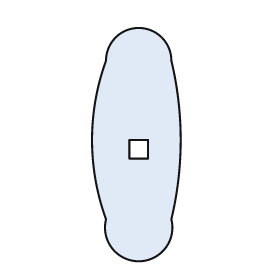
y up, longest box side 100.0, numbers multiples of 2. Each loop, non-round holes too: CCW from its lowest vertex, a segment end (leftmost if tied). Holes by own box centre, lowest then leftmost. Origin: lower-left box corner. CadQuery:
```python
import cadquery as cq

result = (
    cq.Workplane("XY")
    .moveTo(6.0, 18.0)
    .threePointArc((20.0, 0.0), (34.0, 18.0))
    .threePointArc((38.0, 52.0), (34.0, 86.0))
    .threePointArc((20.0, 100.0), (6.0, 86.0))
    .threePointArc((0.0, 52.0), (6.0, 18.0))
    .close()
    .moveTo(16.0, 44.0)
    .lineTo(24.0, 44.0)
    .lineTo(24.0, 52.0)
    .lineTo(16.0, 52.0)
    .close()
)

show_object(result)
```